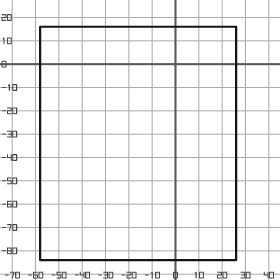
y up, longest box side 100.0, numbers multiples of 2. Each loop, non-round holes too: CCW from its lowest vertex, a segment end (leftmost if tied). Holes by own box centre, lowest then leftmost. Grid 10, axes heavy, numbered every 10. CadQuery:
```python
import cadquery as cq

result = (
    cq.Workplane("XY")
    .moveTo(-58.0, -84.0)
    .lineTo(26.0, -84.0)
    .lineTo(26.0, 16.0)
    .lineTo(-58.0, 16.0)
    .close()
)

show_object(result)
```